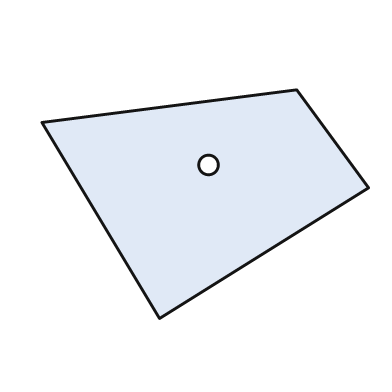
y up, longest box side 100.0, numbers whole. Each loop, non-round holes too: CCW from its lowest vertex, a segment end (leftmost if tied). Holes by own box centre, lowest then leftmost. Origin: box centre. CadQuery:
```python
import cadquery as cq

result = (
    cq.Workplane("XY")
    .moveTo(-14.0, -35.0)
    .lineTo(50.0, 5.0)
    .lineTo(28.0, 35.0)
    .lineTo(-50.0, 25.0)
    .close()
    .moveTo(1.0, 12.0)
    .circle(3.0)
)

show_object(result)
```